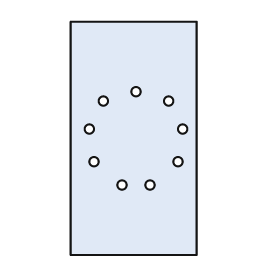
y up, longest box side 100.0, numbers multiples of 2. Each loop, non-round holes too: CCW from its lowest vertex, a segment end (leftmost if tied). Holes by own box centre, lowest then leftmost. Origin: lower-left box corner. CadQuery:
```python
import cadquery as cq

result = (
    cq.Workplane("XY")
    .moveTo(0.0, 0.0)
    .lineTo(54.0, 0.0)
    .lineTo(54.0, 100.0)
    .lineTo(0.0, 100.0)
    .close()
    .moveTo(22.0, 30.0)
    .circle(2.0)
    .moveTo(34.0, 30.0)
    .circle(2.0)
    .moveTo(10.0, 40.0)
    .circle(2.0)
    .moveTo(46.0, 40.0)
    .circle(2.0)
    .moveTo(8.0, 54.0)
    .circle(2.0)
    .moveTo(48.0, 54.0)
    .circle(2.0)
    .moveTo(14.0, 66.0)
    .circle(2.0)
    .moveTo(42.0, 66.0)
    .circle(2.0)
    .moveTo(28.0, 70.0)
    .circle(2.0)
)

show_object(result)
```